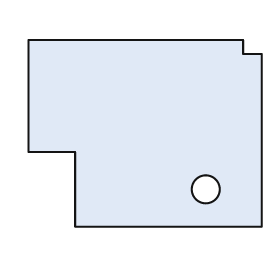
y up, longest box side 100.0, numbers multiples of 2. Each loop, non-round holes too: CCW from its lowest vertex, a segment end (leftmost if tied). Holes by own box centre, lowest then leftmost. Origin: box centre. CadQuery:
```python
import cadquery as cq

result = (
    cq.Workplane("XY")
    .moveTo(-30.0, -40.0)
    .lineTo(50.0, -40.0)
    .lineTo(50.0, 34.0)
    .lineTo(42.0, 34.0)
    .lineTo(42.0, 40.0)
    .lineTo(-50.0, 40.0)
    .lineTo(-50.0, -8.0)
    .lineTo(-30.0, -8.0)
    .close()
    .moveTo(26.0, -24.0)
    .circle(6.0)
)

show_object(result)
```